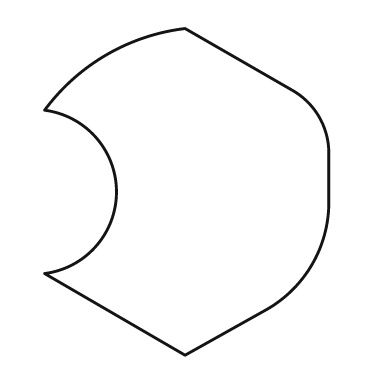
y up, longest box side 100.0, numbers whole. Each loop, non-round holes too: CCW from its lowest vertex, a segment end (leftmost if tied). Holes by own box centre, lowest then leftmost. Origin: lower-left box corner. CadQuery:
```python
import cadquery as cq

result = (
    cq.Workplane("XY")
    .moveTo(43.0, 0.0)
    .lineTo(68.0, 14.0)
    .threePointArc((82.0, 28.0), (87.0, 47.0))
    .lineTo(87.0, 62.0)
    .threePointArc((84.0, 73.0), (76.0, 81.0))
    .lineTo(43.0, 100.0)
    .threePointArc((19.0, 92.0), (0.0, 75.0))
    .threePointArc((22.0, 50.0), (0.0, 25.0))
    .close()
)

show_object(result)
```